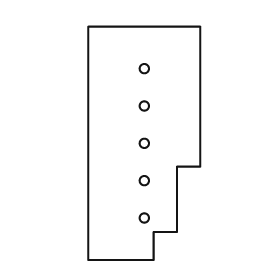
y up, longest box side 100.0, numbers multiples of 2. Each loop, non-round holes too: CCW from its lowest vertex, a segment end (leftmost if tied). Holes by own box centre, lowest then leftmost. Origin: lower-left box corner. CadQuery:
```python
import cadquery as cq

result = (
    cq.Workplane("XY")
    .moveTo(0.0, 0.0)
    .lineTo(28.0, 0.0)
    .lineTo(28.0, 12.0)
    .lineTo(38.0, 12.0)
    .lineTo(38.0, 40.0)
    .lineTo(48.0, 40.0)
    .lineTo(48.0, 100.0)
    .lineTo(0.0, 100.0)
    .close()
    .moveTo(24.0, 18.0)
    .circle(2.0)
    .moveTo(24.0, 34.0)
    .circle(2.0)
    .moveTo(24.0, 50.0)
    .circle(2.0)
    .moveTo(24.0, 66.0)
    .circle(2.0)
    .moveTo(24.0, 82.0)
    .circle(2.0)
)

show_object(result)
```